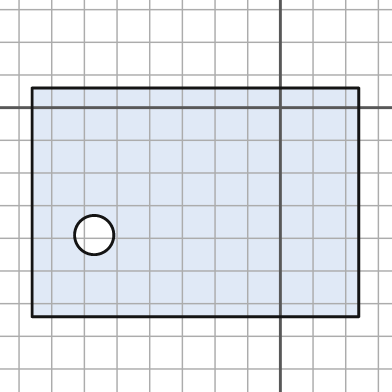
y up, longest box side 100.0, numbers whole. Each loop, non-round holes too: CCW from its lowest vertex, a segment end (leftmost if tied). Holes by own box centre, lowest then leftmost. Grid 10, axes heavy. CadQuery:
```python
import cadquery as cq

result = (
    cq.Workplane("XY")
    .moveTo(-76.0, -64.0)
    .lineTo(24.0, -64.0)
    .lineTo(24.0, 6.0)
    .lineTo(-76.0, 6.0)
    .close()
    .moveTo(-57.0, -39.0)
    .circle(6.0)
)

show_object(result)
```